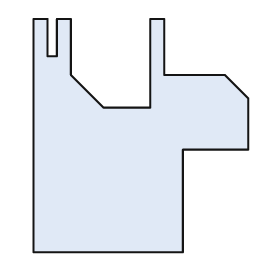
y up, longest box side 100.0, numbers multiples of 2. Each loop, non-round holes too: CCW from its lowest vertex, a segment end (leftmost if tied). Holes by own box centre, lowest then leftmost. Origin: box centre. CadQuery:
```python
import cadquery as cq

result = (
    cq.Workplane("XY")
    .moveTo(-46.0, -50.0)
    .lineTo(18.0, -50.0)
    .lineTo(18.0, -6.0)
    .lineTo(46.0, -6.0)
    .lineTo(46.0, 16.0)
    .lineTo(36.0, 26.0)
    .lineTo(10.0, 26.0)
    .lineTo(10.0, 50.0)
    .lineTo(4.0, 50.0)
    .lineTo(4.0, 12.0)
    .lineTo(-16.0, 12.0)
    .lineTo(-30.0, 26.0)
    .lineTo(-30.0, 50.0)
    .lineTo(-36.0, 50.0)
    .lineTo(-36.0, 34.0)
    .lineTo(-40.0, 34.0)
    .lineTo(-40.0, 50.0)
    .lineTo(-46.0, 50.0)
    .close()
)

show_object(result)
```